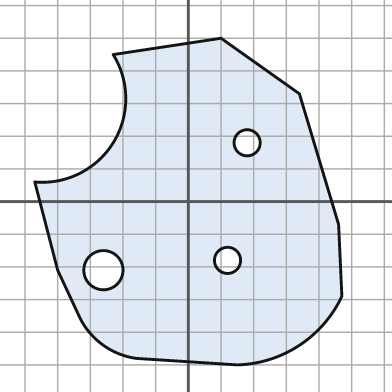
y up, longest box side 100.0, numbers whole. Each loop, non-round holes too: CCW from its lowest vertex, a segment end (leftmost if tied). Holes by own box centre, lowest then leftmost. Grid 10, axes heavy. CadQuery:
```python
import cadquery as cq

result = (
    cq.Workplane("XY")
    .moveTo(15.0, -50.0)
    .threePointArc((34.0, -44.0), (47.0, -29.0))
    .lineTo(46.0, -7.0)
    .lineTo(34.0, 33.0)
    .lineTo(10.0, 50.0)
    .lineTo(-23.0, 45.0)
    .threePointArc((-23.0, 18.0), (-47.0, 6.0))
    .lineTo(-40.0, -21.0)
    .lineTo(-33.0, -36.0)
    .threePointArc((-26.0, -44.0), (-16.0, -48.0))
    .close()
    .moveTo(-26.0, -21.0)
    .circle(6.0)
    .moveTo(12.0, -18.0)
    .circle(4.0)
    .moveTo(18.0, 18.0)
    .circle(4.0)
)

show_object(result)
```